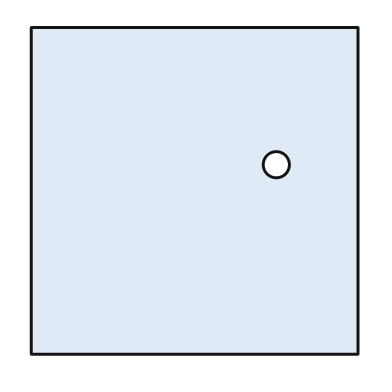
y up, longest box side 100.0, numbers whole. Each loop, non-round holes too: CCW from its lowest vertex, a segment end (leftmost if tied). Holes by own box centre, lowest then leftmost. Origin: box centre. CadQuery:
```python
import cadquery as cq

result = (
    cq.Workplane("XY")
    .moveTo(-50.0, -50.0)
    .lineTo(50.0, -50.0)
    .lineTo(50.0, 50.0)
    .lineTo(-50.0, 50.0)
    .close()
    .moveTo(25.0, 8.0)
    .circle(4.0)
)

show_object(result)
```